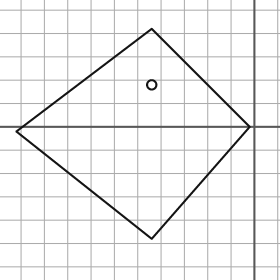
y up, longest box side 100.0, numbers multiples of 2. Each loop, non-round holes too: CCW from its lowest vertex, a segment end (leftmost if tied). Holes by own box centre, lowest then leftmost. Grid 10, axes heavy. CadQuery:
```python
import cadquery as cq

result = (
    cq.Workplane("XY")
    .moveTo(-44.0, -48.0)
    .lineTo(-2.0, 0.0)
    .lineTo(-44.0, 42.0)
    .lineTo(-102.0, -2.0)
    .close()
    .moveTo(-44.0, 18.0)
    .circle(2.0)
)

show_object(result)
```